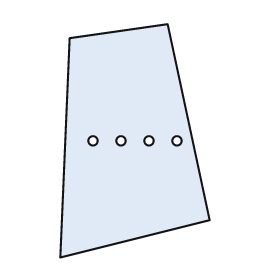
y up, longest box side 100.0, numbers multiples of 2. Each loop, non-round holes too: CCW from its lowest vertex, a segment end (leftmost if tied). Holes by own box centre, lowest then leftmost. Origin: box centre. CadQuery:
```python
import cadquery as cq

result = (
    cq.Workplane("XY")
    .moveTo(-32.0, -50.0)
    .lineTo(32.0, -34.0)
    .lineTo(14.0, 50.0)
    .lineTo(-28.0, 44.0)
    .close()
    .moveTo(-18.0, 0.0)
    .circle(2.0)
    .moveTo(-6.0, 0.0)
    .circle(2.0)
    .moveTo(6.0, 0.0)
    .circle(2.0)
    .moveTo(18.0, 0.0)
    .circle(2.0)
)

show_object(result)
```